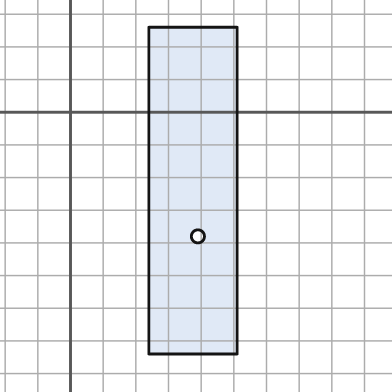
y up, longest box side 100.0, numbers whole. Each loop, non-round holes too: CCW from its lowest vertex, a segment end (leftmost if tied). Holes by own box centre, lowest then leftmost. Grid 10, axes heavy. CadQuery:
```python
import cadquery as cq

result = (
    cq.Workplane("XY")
    .moveTo(24.0, -74.0)
    .lineTo(51.0, -74.0)
    .lineTo(51.0, 26.0)
    .lineTo(24.0, 26.0)
    .close()
    .moveTo(39.0, -38.0)
    .circle(2.0)
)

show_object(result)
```